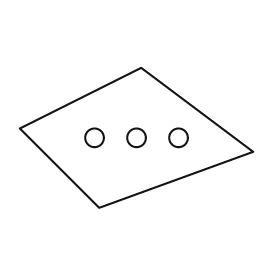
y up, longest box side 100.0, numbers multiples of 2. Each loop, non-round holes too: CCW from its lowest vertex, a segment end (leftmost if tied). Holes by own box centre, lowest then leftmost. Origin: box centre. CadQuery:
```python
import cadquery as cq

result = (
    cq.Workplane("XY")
    .moveTo(-16.0, -30.0)
    .lineTo(50.0, -6.0)
    .lineTo(2.0, 30.0)
    .lineTo(-50.0, 4.0)
    .close()
    .moveTo(-18.0, 0.0)
    .circle(4.0)
    .moveTo(0.0, 0.0)
    .circle(4.0)
    .moveTo(18.0, 0.0)
    .circle(4.0)
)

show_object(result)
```